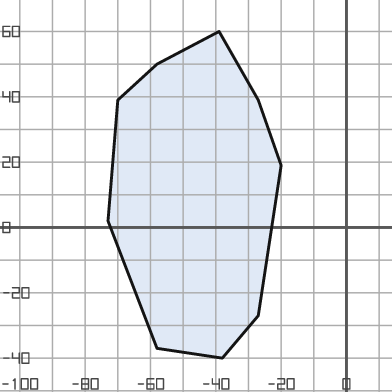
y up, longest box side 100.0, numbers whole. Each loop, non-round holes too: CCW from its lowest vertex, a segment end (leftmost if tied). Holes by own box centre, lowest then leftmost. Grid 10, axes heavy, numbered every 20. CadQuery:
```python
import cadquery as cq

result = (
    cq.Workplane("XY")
    .moveTo(-38.0, -40.0)
    .lineTo(-27.0, -27.0)
    .lineTo(-20.0, 19.0)
    .lineTo(-27.0, 39.0)
    .lineTo(-39.0, 60.0)
    .lineTo(-58.0, 50.0)
    .lineTo(-70.0, 39.0)
    .lineTo(-73.0, 2.0)
    .lineTo(-58.0, -37.0)
    .close()
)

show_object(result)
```